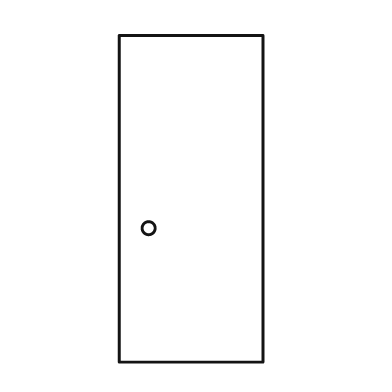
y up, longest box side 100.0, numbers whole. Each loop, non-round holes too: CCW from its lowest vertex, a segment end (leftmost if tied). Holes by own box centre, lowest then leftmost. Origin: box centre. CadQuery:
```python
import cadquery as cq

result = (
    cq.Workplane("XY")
    .moveTo(-22.0, -50.0)
    .lineTo(22.0, -50.0)
    .lineTo(22.0, 50.0)
    .lineTo(-22.0, 50.0)
    .close()
    .moveTo(-13.0, -9.0)
    .circle(2.0)
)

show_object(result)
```